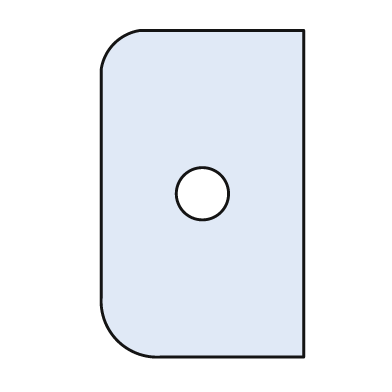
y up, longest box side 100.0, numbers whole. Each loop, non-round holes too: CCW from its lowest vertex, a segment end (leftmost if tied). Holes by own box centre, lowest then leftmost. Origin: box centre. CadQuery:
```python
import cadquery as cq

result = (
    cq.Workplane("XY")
    .moveTo(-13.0, -50.0)
    .lineTo(31.0, -50.0)
    .lineTo(31.0, 50.0)
    .lineTo(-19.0, 50.0)
    .threePointArc((-27.0, 46.0), (-31.0, 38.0))
    .lineTo(-31.0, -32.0)
    .threePointArc((-26.0, -45.0), (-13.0, -50.0))
    .close()
    .moveTo(0.0, 0.0)
    .circle(8.0)
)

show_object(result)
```